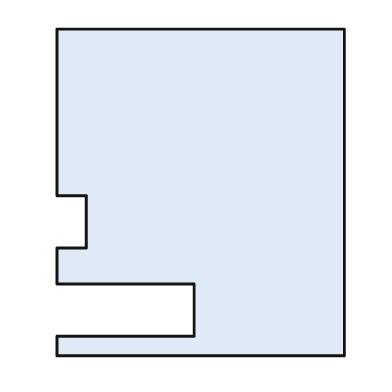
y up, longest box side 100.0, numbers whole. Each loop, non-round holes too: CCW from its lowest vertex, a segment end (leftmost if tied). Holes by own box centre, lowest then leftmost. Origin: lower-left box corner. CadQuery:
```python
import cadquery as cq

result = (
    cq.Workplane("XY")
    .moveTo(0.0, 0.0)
    .lineTo(88.0, 0.0)
    .lineTo(88.0, 100.0)
    .lineTo(0.0, 100.0)
    .lineTo(0.0, 49.0)
    .lineTo(9.0, 49.0)
    .lineTo(9.0, 33.0)
    .lineTo(0.0, 33.0)
    .lineTo(0.0, 22.0)
    .lineTo(42.0, 22.0)
    .lineTo(42.0, 6.0)
    .lineTo(0.0, 6.0)
    .close()
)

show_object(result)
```